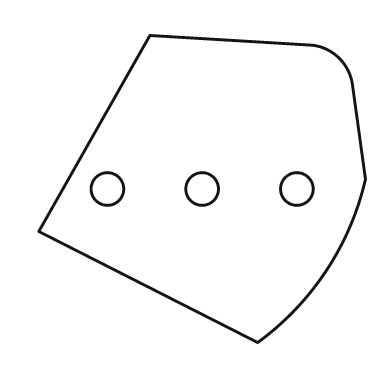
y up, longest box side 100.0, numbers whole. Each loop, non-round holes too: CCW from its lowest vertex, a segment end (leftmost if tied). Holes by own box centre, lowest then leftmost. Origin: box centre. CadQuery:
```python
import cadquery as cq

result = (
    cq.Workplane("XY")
    .moveTo(17.0, -47.0)
    .threePointArc((38.0, -25.0), (50.0, 3.0))
    .lineTo(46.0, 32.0)
    .threePointArc((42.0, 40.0), (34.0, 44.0))
    .lineTo(-16.0, 47.0)
    .lineTo(-50.0, -13.0)
    .close()
    .moveTo(-29.0, 0.0)
    .circle(5.0)
    .moveTo(0.0, 0.0)
    .circle(5.0)
    .moveTo(29.0, 0.0)
    .circle(5.0)
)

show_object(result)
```